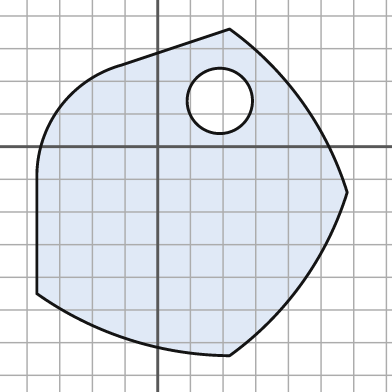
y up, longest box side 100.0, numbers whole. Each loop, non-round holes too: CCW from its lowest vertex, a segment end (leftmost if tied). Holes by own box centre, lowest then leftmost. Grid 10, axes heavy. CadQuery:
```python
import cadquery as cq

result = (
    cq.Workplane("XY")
    .moveTo(22.0, -64.0)
    .threePointArc((44.0, -42.0), (58.0, -14.0))
    .threePointArc((44.0, 14.0), (22.0, 36.0))
    .lineTo(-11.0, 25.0)
    .threePointArc((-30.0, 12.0), (-37.0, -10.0))
    .lineTo(-37.0, -45.0)
    .threePointArc((-9.0, -59.0), (22.0, -64.0))
    .close()
    .moveTo(19.0, 14.0)
    .circle(10.0)
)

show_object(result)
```